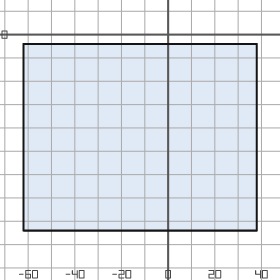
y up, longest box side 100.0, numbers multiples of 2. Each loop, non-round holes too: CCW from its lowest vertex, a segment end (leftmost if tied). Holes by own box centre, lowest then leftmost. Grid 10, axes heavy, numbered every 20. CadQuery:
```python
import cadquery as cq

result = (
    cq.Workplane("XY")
    .moveTo(-62.0, -84.0)
    .lineTo(38.0, -84.0)
    .lineTo(38.0, -4.0)
    .lineTo(-62.0, -4.0)
    .close()
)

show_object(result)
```